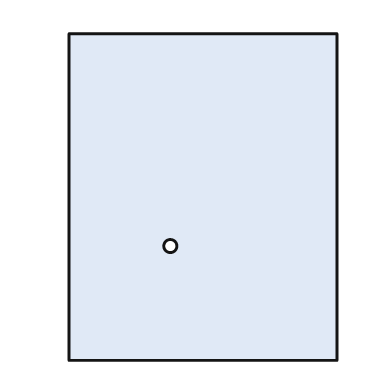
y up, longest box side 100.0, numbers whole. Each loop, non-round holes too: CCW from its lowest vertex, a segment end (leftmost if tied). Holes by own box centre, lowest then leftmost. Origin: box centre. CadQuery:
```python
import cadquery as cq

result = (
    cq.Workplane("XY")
    .moveTo(-41.0, -50.0)
    .lineTo(41.0, -50.0)
    .lineTo(41.0, 50.0)
    .lineTo(-41.0, 50.0)
    .close()
    .moveTo(-10.0, -15.0)
    .circle(2.0)
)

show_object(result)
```